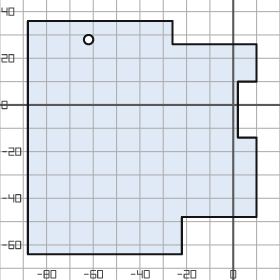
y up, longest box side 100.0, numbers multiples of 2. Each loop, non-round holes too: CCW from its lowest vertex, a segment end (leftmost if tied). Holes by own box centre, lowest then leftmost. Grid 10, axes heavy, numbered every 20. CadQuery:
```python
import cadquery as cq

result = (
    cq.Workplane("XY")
    .moveTo(-88.0, -64.0)
    .lineTo(-22.0, -64.0)
    .lineTo(-22.0, -48.0)
    .lineTo(10.0, -48.0)
    .lineTo(10.0, -14.0)
    .lineTo(2.0, -14.0)
    .lineTo(2.0, 10.0)
    .lineTo(10.0, 10.0)
    .lineTo(10.0, 26.0)
    .lineTo(-26.0, 26.0)
    .lineTo(-26.0, 36.0)
    .lineTo(-88.0, 36.0)
    .close()
    .moveTo(-62.0, 28.0)
    .circle(2.0)
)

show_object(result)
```